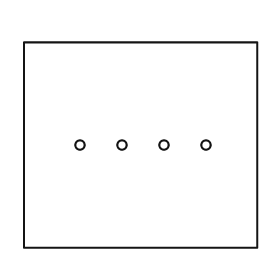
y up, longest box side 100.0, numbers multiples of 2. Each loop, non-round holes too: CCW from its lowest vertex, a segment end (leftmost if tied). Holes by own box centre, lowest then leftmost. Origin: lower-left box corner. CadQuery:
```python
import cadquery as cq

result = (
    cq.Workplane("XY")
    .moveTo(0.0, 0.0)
    .lineTo(100.0, 0.0)
    .lineTo(100.0, 88.0)
    .lineTo(0.0, 88.0)
    .close()
    .moveTo(24.0, 44.0)
    .circle(2.0)
    .moveTo(42.0, 44.0)
    .circle(2.0)
    .moveTo(60.0, 44.0)
    .circle(2.0)
    .moveTo(78.0, 44.0)
    .circle(2.0)
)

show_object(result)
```